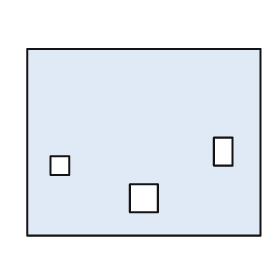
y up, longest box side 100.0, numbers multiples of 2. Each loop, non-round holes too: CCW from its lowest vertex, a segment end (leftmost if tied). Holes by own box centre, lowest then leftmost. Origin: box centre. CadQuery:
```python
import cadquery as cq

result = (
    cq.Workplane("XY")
    .moveTo(-50.0, -40.0)
    .lineTo(50.0, -40.0)
    .lineTo(50.0, 40.0)
    .lineTo(-50.0, 40.0)
    .close()
    .moveTo(-6.0, -30.0)
    .lineTo(6.0, -30.0)
    .lineTo(6.0, -18.0)
    .lineTo(-6.0, -18.0)
    .close()
    .moveTo(-40.0, -14.0)
    .lineTo(-32.0, -14.0)
    .lineTo(-32.0, -6.0)
    .lineTo(-40.0, -6.0)
    .close()
    .moveTo(30.0, -10.0)
    .lineTo(38.0, -10.0)
    .lineTo(38.0, 2.0)
    .lineTo(30.0, 2.0)
    .close()
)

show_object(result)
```